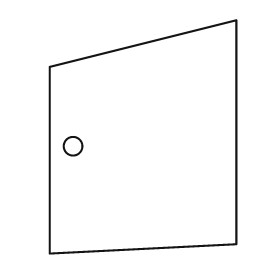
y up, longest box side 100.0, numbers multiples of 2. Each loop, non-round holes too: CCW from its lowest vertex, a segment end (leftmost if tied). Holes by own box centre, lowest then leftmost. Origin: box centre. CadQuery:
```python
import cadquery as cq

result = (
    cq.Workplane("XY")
    .moveTo(-40.0, -50.0)
    .lineTo(40.0, -46.0)
    .lineTo(40.0, 50.0)
    .lineTo(-40.0, 30.0)
    .close()
    .moveTo(-30.0, -4.0)
    .circle(4.0)
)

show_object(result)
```